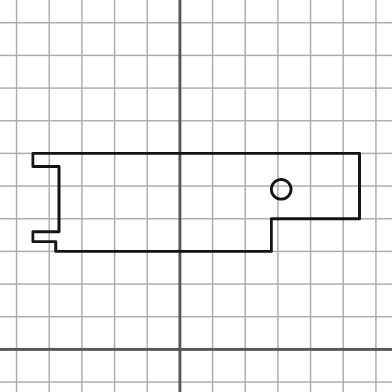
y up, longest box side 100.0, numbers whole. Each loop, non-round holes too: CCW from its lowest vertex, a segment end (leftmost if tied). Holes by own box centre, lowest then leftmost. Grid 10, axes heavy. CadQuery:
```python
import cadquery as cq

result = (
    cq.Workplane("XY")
    .moveTo(-38.0, 30.0)
    .lineTo(28.0, 30.0)
    .lineTo(28.0, 40.0)
    .lineTo(55.0, 40.0)
    .lineTo(55.0, 60.0)
    .lineTo(-45.0, 60.0)
    .lineTo(-45.0, 56.0)
    .lineTo(-37.0, 56.0)
    .lineTo(-37.0, 36.0)
    .lineTo(-45.0, 36.0)
    .lineTo(-45.0, 33.0)
    .lineTo(-38.0, 33.0)
    .close()
    .moveTo(31.0, 49.0)
    .circle(3.0)
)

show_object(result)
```